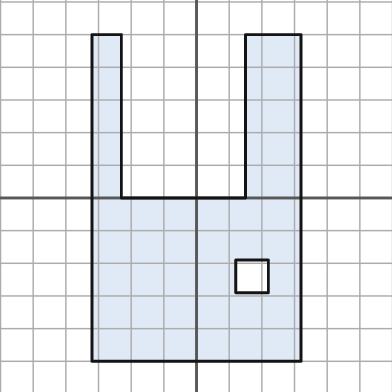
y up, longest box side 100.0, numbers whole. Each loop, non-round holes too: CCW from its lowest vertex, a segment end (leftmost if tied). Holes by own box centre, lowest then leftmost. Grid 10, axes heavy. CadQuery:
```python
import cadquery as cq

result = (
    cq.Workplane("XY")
    .moveTo(-32.0, -50.0)
    .lineTo(32.0, -50.0)
    .lineTo(32.0, 50.0)
    .lineTo(15.0, 50.0)
    .lineTo(15.0, 0.0)
    .lineTo(-23.0, 0.0)
    .lineTo(-23.0, 50.0)
    .lineTo(-32.0, 50.0)
    .close()
    .moveTo(12.0, -29.0)
    .lineTo(22.0, -29.0)
    .lineTo(22.0, -19.0)
    .lineTo(12.0, -19.0)
    .close()
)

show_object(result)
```